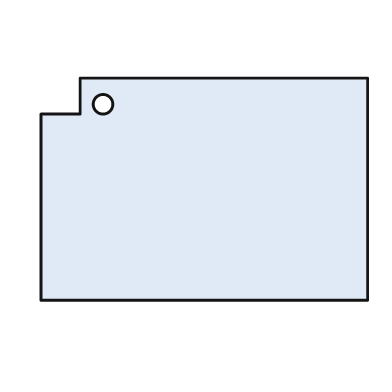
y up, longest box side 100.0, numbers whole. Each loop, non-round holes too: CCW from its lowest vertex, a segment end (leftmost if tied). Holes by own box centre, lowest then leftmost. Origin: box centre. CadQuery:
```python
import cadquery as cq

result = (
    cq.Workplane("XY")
    .moveTo(-50.0, -34.0)
    .lineTo(50.0, -34.0)
    .lineTo(50.0, 34.0)
    .lineTo(-38.0, 34.0)
    .lineTo(-38.0, 23.0)
    .lineTo(-50.0, 23.0)
    .close()
    .moveTo(-31.0, 26.0)
    .circle(3.0)
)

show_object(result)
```